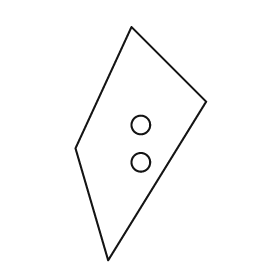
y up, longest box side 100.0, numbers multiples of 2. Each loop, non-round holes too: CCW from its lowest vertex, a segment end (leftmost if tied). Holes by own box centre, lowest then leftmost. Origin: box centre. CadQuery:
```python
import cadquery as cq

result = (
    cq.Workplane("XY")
    .moveTo(-14.0, -50.0)
    .lineTo(28.0, 18.0)
    .lineTo(-4.0, 50.0)
    .lineTo(-28.0, -2.0)
    .close()
    .moveTo(0.0, -8.0)
    .circle(4.0)
    .moveTo(0.0, 8.0)
    .circle(4.0)
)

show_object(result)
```